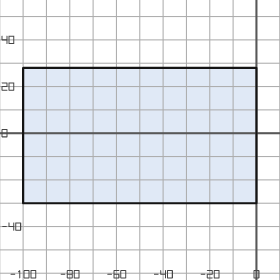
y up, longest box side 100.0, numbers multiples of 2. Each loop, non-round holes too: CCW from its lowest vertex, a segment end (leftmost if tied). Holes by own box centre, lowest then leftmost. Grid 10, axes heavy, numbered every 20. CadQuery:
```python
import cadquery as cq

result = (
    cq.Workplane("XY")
    .moveTo(-100.0, -30.0)
    .lineTo(0.0, -30.0)
    .lineTo(0.0, 28.0)
    .lineTo(-100.0, 28.0)
    .close()
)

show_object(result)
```